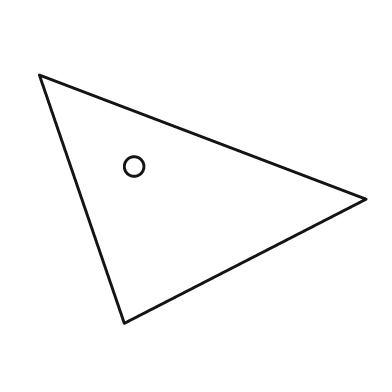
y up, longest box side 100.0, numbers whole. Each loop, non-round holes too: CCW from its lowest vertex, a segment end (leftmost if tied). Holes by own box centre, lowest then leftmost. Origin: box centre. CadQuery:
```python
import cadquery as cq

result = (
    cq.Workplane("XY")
    .moveTo(-24.0, -38.0)
    .lineTo(50.0, 0.0)
    .lineTo(-50.0, 38.0)
    .close()
    .moveTo(-21.0, 10.0)
    .circle(3.0)
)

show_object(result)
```